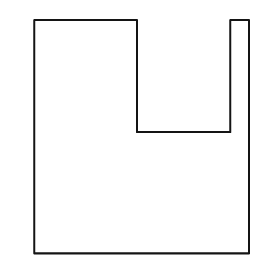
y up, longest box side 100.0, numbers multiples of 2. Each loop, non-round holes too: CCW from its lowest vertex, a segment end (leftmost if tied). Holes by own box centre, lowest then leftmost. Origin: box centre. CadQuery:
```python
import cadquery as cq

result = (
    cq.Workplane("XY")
    .moveTo(-46.0, -50.0)
    .lineTo(46.0, -50.0)
    .lineTo(46.0, 50.0)
    .lineTo(38.0, 50.0)
    .lineTo(38.0, 2.0)
    .lineTo(-2.0, 2.0)
    .lineTo(-2.0, 50.0)
    .lineTo(-46.0, 50.0)
    .close()
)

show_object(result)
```